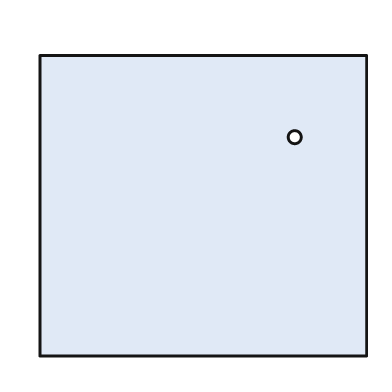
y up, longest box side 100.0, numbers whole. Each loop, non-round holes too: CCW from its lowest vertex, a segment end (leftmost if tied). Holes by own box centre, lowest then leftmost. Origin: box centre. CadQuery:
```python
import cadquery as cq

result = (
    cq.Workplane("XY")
    .moveTo(-50.0, -46.0)
    .lineTo(50.0, -46.0)
    .lineTo(50.0, 46.0)
    .lineTo(-50.0, 46.0)
    .close()
    .moveTo(28.0, 21.0)
    .circle(2.0)
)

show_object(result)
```